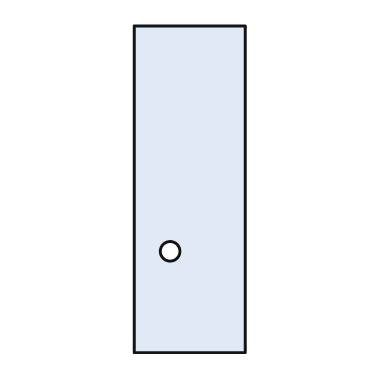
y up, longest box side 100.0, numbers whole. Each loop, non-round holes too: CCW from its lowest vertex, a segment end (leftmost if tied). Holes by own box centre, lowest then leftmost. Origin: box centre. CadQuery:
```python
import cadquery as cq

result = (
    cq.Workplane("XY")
    .moveTo(-17.0, -50.0)
    .lineTo(17.0, -50.0)
    .lineTo(17.0, 50.0)
    .lineTo(-17.0, 50.0)
    .close()
    .moveTo(-6.0, -19.0)
    .circle(3.0)
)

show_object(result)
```